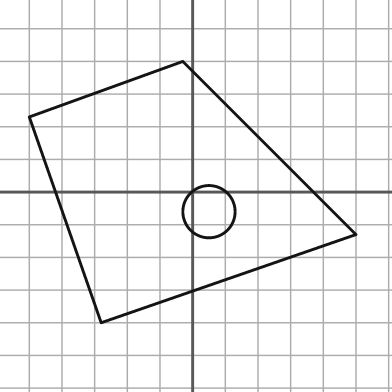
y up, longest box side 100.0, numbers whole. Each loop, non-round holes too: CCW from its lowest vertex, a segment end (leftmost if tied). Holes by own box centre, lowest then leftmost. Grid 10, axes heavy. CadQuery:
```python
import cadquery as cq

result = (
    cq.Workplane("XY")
    .moveTo(-28.0, -40.0)
    .lineTo(50.0, -13.0)
    .lineTo(-3.0, 40.0)
    .lineTo(-50.0, 23.0)
    .close()
    .moveTo(5.0, -6.0)
    .circle(8.0)
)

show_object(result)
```